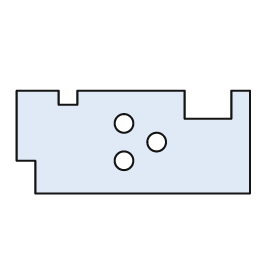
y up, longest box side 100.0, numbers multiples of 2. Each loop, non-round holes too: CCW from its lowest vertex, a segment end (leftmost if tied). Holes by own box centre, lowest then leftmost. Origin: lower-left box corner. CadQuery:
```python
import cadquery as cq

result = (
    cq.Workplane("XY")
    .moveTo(8.0, 0.0)
    .lineTo(100.0, 0.0)
    .lineTo(100.0, 44.0)
    .lineTo(92.0, 44.0)
    .lineTo(92.0, 32.0)
    .lineTo(72.0, 32.0)
    .lineTo(72.0, 44.0)
    .lineTo(26.0, 44.0)
    .lineTo(26.0, 38.0)
    .lineTo(18.0, 38.0)
    .lineTo(18.0, 44.0)
    .lineTo(0.0, 44.0)
    .lineTo(0.0, 14.0)
    .lineTo(8.0, 14.0)
    .close()
    .moveTo(46.0, 14.0)
    .circle(4.0)
    .moveTo(60.0, 22.0)
    .circle(4.0)
    .moveTo(46.0, 30.0)
    .circle(4.0)
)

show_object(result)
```